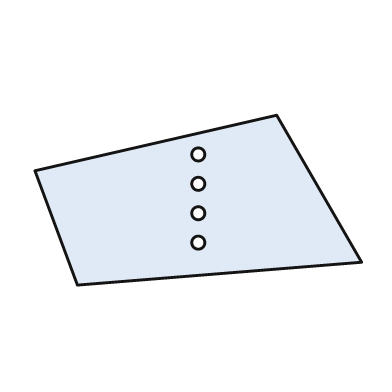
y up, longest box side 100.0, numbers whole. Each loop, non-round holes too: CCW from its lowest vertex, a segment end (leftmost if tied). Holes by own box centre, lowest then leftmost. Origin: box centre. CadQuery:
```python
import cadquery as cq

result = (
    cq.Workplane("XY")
    .moveTo(-37.0, -26.0)
    .lineTo(50.0, -19.0)
    .lineTo(24.0, 26.0)
    .lineTo(-50.0, 9.0)
    .close()
    .moveTo(0.0, -13.0)
    .circle(2.0)
    .moveTo(0.0, -4.0)
    .circle(2.0)
    .moveTo(0.0, 5.0)
    .circle(2.0)
    .moveTo(0.0, 14.0)
    .circle(2.0)
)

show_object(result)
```